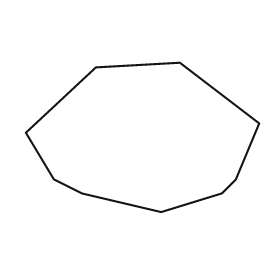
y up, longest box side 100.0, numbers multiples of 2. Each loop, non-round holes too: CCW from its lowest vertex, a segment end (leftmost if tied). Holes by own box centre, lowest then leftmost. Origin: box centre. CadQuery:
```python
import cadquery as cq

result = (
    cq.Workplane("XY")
    .moveTo(8.0, -32.0)
    .lineTo(34.0, -24.0)
    .lineTo(40.0, -18.0)
    .lineTo(50.0, 6.0)
    .lineTo(16.0, 32.0)
    .lineTo(-20.0, 30.0)
    .lineTo(-50.0, 2.0)
    .lineTo(-38.0, -18.0)
    .lineTo(-26.0, -24.0)
    .close()
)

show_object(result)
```